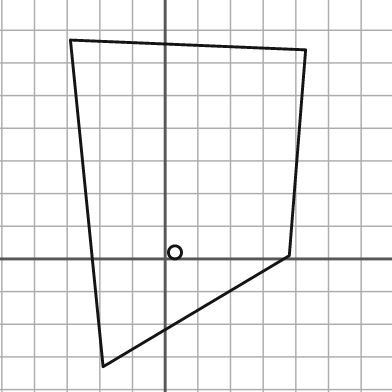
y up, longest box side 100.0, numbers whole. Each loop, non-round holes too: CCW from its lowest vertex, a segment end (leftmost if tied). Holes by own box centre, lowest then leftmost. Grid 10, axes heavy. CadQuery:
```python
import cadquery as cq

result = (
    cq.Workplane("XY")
    .moveTo(-19.0, -33.0)
    .lineTo(38.0, 1.0)
    .lineTo(43.0, 64.0)
    .lineTo(-29.0, 67.0)
    .close()
    .moveTo(3.0, 2.0)
    .circle(2.0)
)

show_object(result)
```